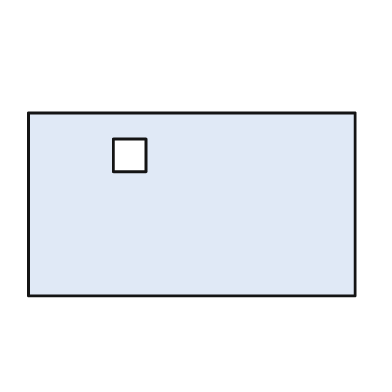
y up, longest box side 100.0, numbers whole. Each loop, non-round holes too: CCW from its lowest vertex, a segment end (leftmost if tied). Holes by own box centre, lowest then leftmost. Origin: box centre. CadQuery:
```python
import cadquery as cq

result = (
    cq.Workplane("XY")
    .moveTo(-50.0, -28.0)
    .lineTo(50.0, -28.0)
    .lineTo(50.0, 28.0)
    .lineTo(-50.0, 28.0)
    .close()
    .moveTo(-24.0, 10.0)
    .lineTo(-14.0, 10.0)
    .lineTo(-14.0, 20.0)
    .lineTo(-24.0, 20.0)
    .close()
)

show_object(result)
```